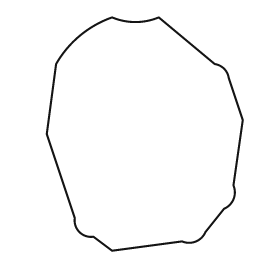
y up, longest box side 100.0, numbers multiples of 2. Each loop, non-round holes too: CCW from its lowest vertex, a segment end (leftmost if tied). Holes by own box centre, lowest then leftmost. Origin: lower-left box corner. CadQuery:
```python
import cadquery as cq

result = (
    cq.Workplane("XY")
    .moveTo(28.0, 0.0)
    .lineTo(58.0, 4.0)
    .threePointArc((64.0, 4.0), (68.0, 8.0))
    .lineTo(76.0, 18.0)
    .threePointArc((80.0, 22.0), (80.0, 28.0))
    .lineTo(84.0, 56.0)
    .lineTo(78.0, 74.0)
    .threePointArc((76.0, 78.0), (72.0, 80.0))
    .lineTo(48.0, 100.0)
    .threePointArc((38.0, 98.0), (28.0, 100.0))
    .threePointArc((14.0, 92.0), (4.0, 80.0))
    .lineTo(0.0, 50.0)
    .lineTo(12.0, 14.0)
    .threePointArc((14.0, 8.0), (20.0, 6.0))
    .close()
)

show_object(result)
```